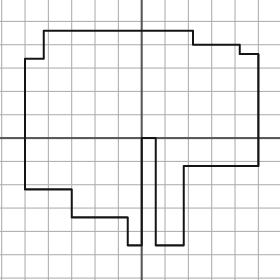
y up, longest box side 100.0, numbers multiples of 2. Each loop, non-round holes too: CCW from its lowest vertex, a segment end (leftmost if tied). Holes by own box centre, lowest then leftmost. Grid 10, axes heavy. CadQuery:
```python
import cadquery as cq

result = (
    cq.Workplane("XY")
    .moveTo(-6.0, -46.0)
    .lineTo(0.0, -46.0)
    .lineTo(0.0, 0.0)
    .lineTo(6.0, 0.0)
    .lineTo(6.0, -46.0)
    .lineTo(18.0, -46.0)
    .lineTo(18.0, -12.0)
    .lineTo(50.0, -12.0)
    .lineTo(50.0, 36.0)
    .lineTo(42.0, 36.0)
    .lineTo(42.0, 40.0)
    .lineTo(22.0, 40.0)
    .lineTo(22.0, 46.0)
    .lineTo(-42.0, 46.0)
    .lineTo(-42.0, 34.0)
    .lineTo(-50.0, 34.0)
    .lineTo(-50.0, -22.0)
    .lineTo(-30.0, -22.0)
    .lineTo(-30.0, -34.0)
    .lineTo(-6.0, -34.0)
    .close()
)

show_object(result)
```